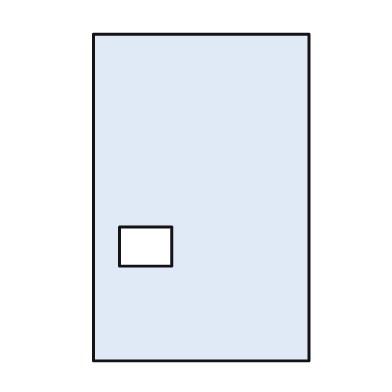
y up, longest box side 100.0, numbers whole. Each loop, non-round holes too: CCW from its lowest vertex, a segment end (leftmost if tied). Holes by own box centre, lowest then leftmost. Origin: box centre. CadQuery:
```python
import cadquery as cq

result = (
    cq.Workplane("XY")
    .moveTo(-33.0, -50.0)
    .lineTo(33.0, -50.0)
    .lineTo(33.0, 50.0)
    .lineTo(-33.0, 50.0)
    .close()
    .moveTo(-25.0, -21.0)
    .lineTo(-9.0, -21.0)
    .lineTo(-9.0, -9.0)
    .lineTo(-25.0, -9.0)
    .close()
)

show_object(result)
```